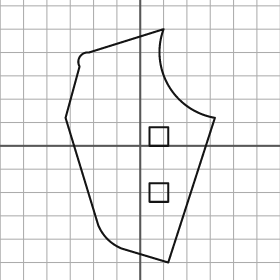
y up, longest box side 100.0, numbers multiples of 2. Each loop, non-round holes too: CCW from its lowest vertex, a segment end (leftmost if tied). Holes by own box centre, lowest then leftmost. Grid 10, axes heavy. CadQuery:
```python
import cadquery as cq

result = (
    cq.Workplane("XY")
    .moveTo(12.0, -50.0)
    .lineTo(32.0, 12.0)
    .threePointArc((12.0, 26.0), (10.0, 50.0))
    .lineTo(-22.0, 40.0)
    .threePointArc((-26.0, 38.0), (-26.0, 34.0))
    .lineTo(-32.0, 12.0)
    .lineTo(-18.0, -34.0)
    .threePointArc((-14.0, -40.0), (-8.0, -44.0))
    .close()
    .moveTo(4.0, -24.0)
    .lineTo(12.0, -24.0)
    .lineTo(12.0, -16.0)
    .lineTo(4.0, -16.0)
    .close()
    .moveTo(4.0, 0.0)
    .lineTo(12.0, 0.0)
    .lineTo(12.0, 8.0)
    .lineTo(4.0, 8.0)
    .close()
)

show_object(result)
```